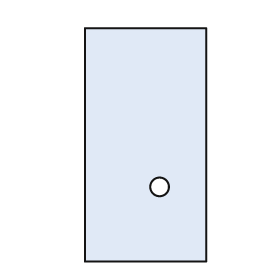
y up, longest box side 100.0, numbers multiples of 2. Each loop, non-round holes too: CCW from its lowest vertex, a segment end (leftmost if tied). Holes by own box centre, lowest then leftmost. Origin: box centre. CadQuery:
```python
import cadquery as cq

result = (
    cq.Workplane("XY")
    .moveTo(-26.0, -50.0)
    .lineTo(26.0, -50.0)
    .lineTo(26.0, 50.0)
    .lineTo(-26.0, 50.0)
    .close()
    .moveTo(6.0, -18.0)
    .circle(4.0)
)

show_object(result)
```